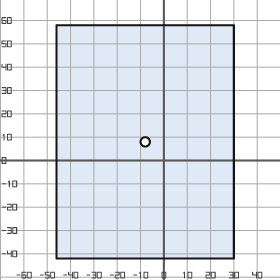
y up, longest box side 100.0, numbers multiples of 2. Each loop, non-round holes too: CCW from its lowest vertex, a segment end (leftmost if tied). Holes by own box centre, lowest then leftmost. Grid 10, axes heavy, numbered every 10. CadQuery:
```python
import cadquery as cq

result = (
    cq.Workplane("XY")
    .moveTo(-46.0, -42.0)
    .lineTo(30.0, -42.0)
    .lineTo(30.0, 58.0)
    .lineTo(-46.0, 58.0)
    .close()
    .moveTo(-8.0, 8.0)
    .circle(2.0)
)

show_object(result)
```